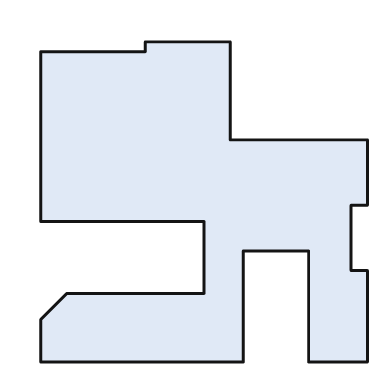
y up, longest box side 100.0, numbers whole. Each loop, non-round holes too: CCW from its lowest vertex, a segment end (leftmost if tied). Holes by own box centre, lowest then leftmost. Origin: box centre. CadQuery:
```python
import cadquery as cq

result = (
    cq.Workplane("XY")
    .moveTo(-50.0, -49.0)
    .lineTo(12.0, -49.0)
    .lineTo(12.0, -15.0)
    .lineTo(32.0, -15.0)
    .lineTo(32.0, -49.0)
    .lineTo(50.0, -49.0)
    .lineTo(50.0, -21.0)
    .lineTo(45.0, -21.0)
    .lineTo(45.0, -1.0)
    .lineTo(50.0, -1.0)
    .lineTo(50.0, 19.0)
    .lineTo(8.0, 19.0)
    .lineTo(8.0, 49.0)
    .lineTo(-18.0, 49.0)
    .lineTo(-18.0, 46.0)
    .lineTo(-50.0, 46.0)
    .lineTo(-50.0, -6.0)
    .lineTo(0.0, -6.0)
    .lineTo(0.0, -28.0)
    .lineTo(-42.0, -28.0)
    .lineTo(-50.0, -36.0)
    .close()
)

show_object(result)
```